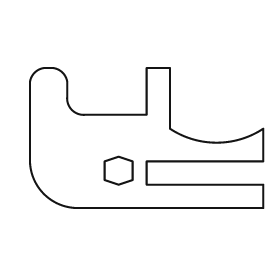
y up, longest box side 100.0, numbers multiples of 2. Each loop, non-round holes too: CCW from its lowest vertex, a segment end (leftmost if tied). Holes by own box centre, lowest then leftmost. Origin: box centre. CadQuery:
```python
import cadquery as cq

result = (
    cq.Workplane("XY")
    .moveTo(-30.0, -30.0)
    .lineTo(50.0, -30.0)
    .lineTo(50.0, -20.0)
    .lineTo(0.0, -20.0)
    .lineTo(0.0, -10.0)
    .lineTo(50.0, -10.0)
    .lineTo(50.0, 4.0)
    .threePointArc((30.0, -2.0), (10.0, 4.0))
    .lineTo(10.0, 30.0)
    .lineTo(0.0, 30.0)
    .lineTo(0.0, 10.0)
    .lineTo(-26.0, 10.0)
    .threePointArc((-32.0, 12.0), (-34.0, 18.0))
    .lineTo(-34.0, 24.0)
    .threePointArc((-36.0, 28.0), (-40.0, 30.0))
    .lineTo(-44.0, 30.0)
    .threePointArc((-48.0, 28.0), (-50.0, 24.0))
    .lineTo(-50.0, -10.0)
    .threePointArc((-44.0, -24.0), (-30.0, -30.0))
    .close()
    .moveTo(-12.0, -20.0)
    .lineTo(-6.0, -18.0)
    .lineTo(-6.0, -10.0)
    .lineTo(-12.0, -8.0)
    .lineTo(-18.0, -10.0)
    .lineTo(-18.0, -18.0)
    .close()
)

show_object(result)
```